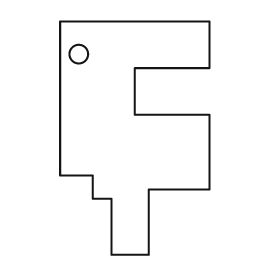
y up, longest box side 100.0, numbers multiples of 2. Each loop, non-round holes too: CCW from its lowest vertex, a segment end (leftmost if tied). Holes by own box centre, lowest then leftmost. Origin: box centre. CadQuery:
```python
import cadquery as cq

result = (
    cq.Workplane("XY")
    .moveTo(-10.0, -50.0)
    .lineTo(6.0, -50.0)
    .lineTo(6.0, -22.0)
    .lineTo(32.0, -22.0)
    .lineTo(32.0, 10.0)
    .lineTo(0.0, 10.0)
    .lineTo(0.0, 30.0)
    .lineTo(32.0, 30.0)
    .lineTo(32.0, 50.0)
    .lineTo(-32.0, 50.0)
    .lineTo(-32.0, -16.0)
    .lineTo(-18.0, -16.0)
    .lineTo(-18.0, -26.0)
    .lineTo(-10.0, -26.0)
    .close()
    .moveTo(-24.0, 36.0)
    .circle(4.0)
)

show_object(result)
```